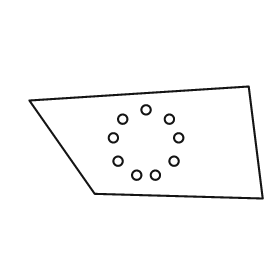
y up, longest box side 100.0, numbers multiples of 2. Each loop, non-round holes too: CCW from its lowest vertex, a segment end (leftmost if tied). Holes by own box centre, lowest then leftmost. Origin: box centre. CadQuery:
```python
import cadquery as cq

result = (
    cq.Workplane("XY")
    .moveTo(50.0, -24.0)
    .lineTo(44.0, 24.0)
    .lineTo(-50.0, 18.0)
    .lineTo(-22.0, -22.0)
    .close()
    .moveTo(-4.0, -14.0)
    .circle(2.0)
    .moveTo(4.0, -14.0)
    .circle(2.0)
    .moveTo(-12.0, -8.0)
    .circle(2.0)
    .moveTo(12.0, -8.0)
    .circle(2.0)
    .moveTo(-14.0, 2.0)
    .circle(2.0)
    .moveTo(14.0, 2.0)
    .circle(2.0)
    .moveTo(-10.0, 10.0)
    .circle(2.0)
    .moveTo(10.0, 10.0)
    .circle(2.0)
    .moveTo(0.0, 14.0)
    .circle(2.0)
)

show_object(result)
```